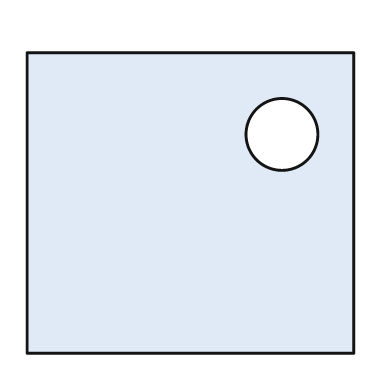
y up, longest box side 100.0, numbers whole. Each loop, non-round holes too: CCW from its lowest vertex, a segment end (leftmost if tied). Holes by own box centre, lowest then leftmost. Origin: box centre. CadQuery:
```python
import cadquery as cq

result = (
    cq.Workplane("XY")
    .moveTo(-50.0, -46.0)
    .lineTo(50.0, -46.0)
    .lineTo(50.0, 46.0)
    .lineTo(-50.0, 46.0)
    .close()
    .moveTo(28.0, 21.0)
    .circle(11.0)
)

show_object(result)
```